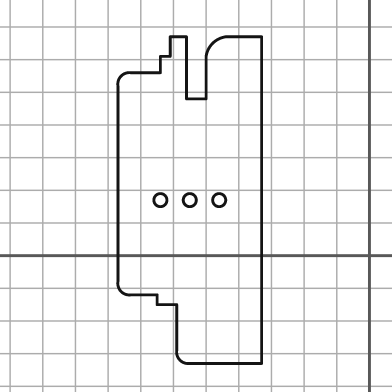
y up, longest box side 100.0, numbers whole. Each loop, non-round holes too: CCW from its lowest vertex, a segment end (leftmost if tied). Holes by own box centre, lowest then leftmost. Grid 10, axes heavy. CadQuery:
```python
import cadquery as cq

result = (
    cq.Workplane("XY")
    .moveTo(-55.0, -33.0)
    .lineTo(-33.0, -33.0)
    .lineTo(-33.0, 67.0)
    .lineTo(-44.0, 67.0)
    .threePointArc((-48.0, 65.0), (-50.0, 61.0))
    .lineTo(-50.0, 48.0)
    .lineTo(-56.0, 48.0)
    .lineTo(-56.0, 67.0)
    .lineTo(-61.0, 67.0)
    .lineTo(-61.0, 61.0)
    .lineTo(-64.0, 61.0)
    .lineTo(-64.0, 56.0)
    .lineTo(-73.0, 56.0)
    .threePointArc((-76.0, 55.0), (-77.0, 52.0))
    .lineTo(-77.0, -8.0)
    .threePointArc((-76.0, -11.0), (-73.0, -12.0))
    .lineTo(-65.0, -12.0)
    .lineTo(-65.0, -15.0)
    .lineTo(-59.0, -15.0)
    .lineTo(-59.0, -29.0)
    .threePointArc((-58.0, -32.0), (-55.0, -33.0))
    .close()
    .moveTo(-64.0, 17.0)
    .circle(2.0)
    .moveTo(-55.0, 17.0)
    .circle(2.0)
    .moveTo(-46.0, 17.0)
    .circle(2.0)
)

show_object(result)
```